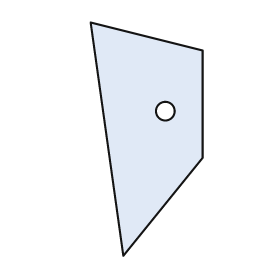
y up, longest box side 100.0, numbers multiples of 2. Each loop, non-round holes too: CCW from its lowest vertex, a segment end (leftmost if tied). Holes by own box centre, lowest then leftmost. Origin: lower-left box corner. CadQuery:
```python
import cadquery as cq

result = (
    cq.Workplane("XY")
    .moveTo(14.0, 0.0)
    .lineTo(48.0, 42.0)
    .lineTo(48.0, 88.0)
    .lineTo(0.0, 100.0)
    .close()
    .moveTo(32.0, 62.0)
    .circle(4.0)
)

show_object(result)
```